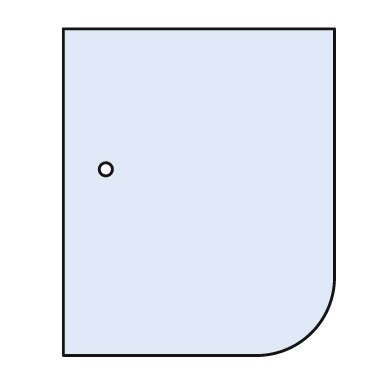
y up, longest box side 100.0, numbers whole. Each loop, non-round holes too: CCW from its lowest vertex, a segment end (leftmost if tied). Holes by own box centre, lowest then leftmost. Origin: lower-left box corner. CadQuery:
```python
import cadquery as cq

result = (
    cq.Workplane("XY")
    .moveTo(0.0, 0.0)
    .lineTo(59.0, 0.0)
    .threePointArc((76.0, 7.0), (83.0, 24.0))
    .lineTo(83.0, 100.0)
    .lineTo(0.0, 100.0)
    .close()
    .moveTo(13.0, 57.0)
    .circle(2.0)
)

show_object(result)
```